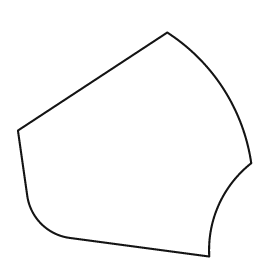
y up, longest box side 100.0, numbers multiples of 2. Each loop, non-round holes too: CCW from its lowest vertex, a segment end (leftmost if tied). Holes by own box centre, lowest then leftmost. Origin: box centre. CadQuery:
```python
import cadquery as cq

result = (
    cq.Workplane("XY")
    .moveTo(32.0, -48.0)
    .threePointArc((36.0, -26.0), (50.0, -8.0))
    .threePointArc((38.0, 24.0), (14.0, 48.0))
    .lineTo(-50.0, 6.0)
    .lineTo(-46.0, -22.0)
    .threePointArc((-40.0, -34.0), (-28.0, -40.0))
    .close()
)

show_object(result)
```